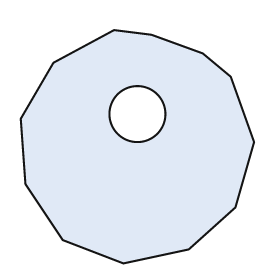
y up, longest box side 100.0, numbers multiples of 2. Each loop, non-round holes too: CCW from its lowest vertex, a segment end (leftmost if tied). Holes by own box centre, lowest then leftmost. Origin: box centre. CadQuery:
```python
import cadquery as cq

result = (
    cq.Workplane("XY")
    .moveTo(-6.0, -50.0)
    .lineTo(22.0, -44.0)
    .lineTo(42.0, -26.0)
    .lineTo(50.0, 2.0)
    .lineTo(40.0, 30.0)
    .lineTo(28.0, 40.0)
    .lineTo(6.0, 48.0)
    .lineTo(-10.0, 50.0)
    .lineTo(-36.0, 36.0)
    .lineTo(-50.0, 12.0)
    .lineTo(-48.0, -16.0)
    .lineTo(-32.0, -40.0)
    .close()
    .moveTo(0.0, 14.0)
    .circle(12.0)
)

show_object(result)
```